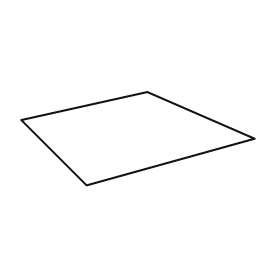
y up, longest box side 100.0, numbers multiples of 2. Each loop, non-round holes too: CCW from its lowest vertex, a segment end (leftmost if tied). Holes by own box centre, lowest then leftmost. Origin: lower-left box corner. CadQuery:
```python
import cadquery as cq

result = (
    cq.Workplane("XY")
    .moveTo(28.0, 0.0)
    .lineTo(100.0, 20.0)
    .lineTo(54.0, 40.0)
    .lineTo(0.0, 28.0)
    .close()
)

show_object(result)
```